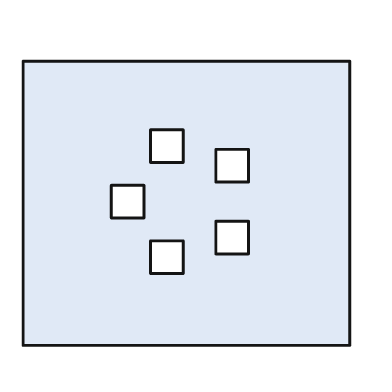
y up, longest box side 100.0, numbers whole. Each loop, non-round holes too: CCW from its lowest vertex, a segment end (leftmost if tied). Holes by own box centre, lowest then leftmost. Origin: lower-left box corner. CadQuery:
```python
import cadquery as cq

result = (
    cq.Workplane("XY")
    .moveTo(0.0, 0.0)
    .lineTo(100.0, 0.0)
    .lineTo(100.0, 87.0)
    .lineTo(0.0, 87.0)
    .close()
    .moveTo(39.0, 22.0)
    .lineTo(49.0, 22.0)
    .lineTo(49.0, 32.0)
    .lineTo(39.0, 32.0)
    .close()
    .moveTo(59.0, 28.0)
    .lineTo(69.0, 28.0)
    .lineTo(69.0, 38.0)
    .lineTo(59.0, 38.0)
    .close()
    .moveTo(27.0, 39.0)
    .lineTo(37.0, 39.0)
    .lineTo(37.0, 49.0)
    .lineTo(27.0, 49.0)
    .close()
    .moveTo(59.0, 50.0)
    .lineTo(69.0, 50.0)
    .lineTo(69.0, 60.0)
    .lineTo(59.0, 60.0)
    .close()
    .moveTo(39.0, 56.0)
    .lineTo(49.0, 56.0)
    .lineTo(49.0, 66.0)
    .lineTo(39.0, 66.0)
    .close()
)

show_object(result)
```